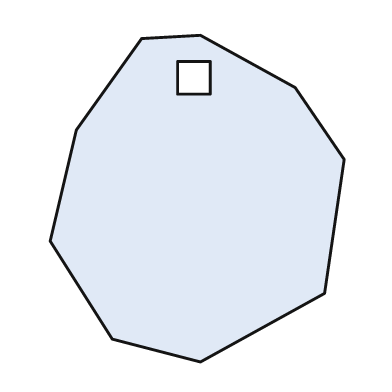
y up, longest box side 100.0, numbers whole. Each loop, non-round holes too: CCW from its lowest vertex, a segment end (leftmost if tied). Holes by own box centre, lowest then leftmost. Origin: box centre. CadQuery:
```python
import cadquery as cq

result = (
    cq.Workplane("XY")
    .moveTo(1.0, -50.0)
    .lineTo(39.0, -29.0)
    .lineTo(45.0, 12.0)
    .lineTo(30.0, 34.0)
    .lineTo(1.0, 50.0)
    .lineTo(-17.0, 49.0)
    .lineTo(-37.0, 21.0)
    .lineTo(-45.0, -13.0)
    .lineTo(-26.0, -43.0)
    .close()
    .moveTo(-6.0, 32.0)
    .lineTo(4.0, 32.0)
    .lineTo(4.0, 42.0)
    .lineTo(-6.0, 42.0)
    .close()
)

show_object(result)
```